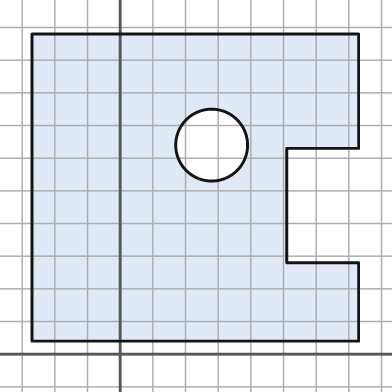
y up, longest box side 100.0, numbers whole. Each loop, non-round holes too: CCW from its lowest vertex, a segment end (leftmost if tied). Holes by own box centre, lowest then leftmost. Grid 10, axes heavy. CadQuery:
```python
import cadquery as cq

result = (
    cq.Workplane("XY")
    .moveTo(-27.0, 4.0)
    .lineTo(73.0, 4.0)
    .lineTo(73.0, 28.0)
    .lineTo(51.0, 28.0)
    .lineTo(51.0, 63.0)
    .lineTo(73.0, 63.0)
    .lineTo(73.0, 98.0)
    .lineTo(-27.0, 98.0)
    .close()
    .moveTo(28.0, 64.0)
    .circle(11.0)
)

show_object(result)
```